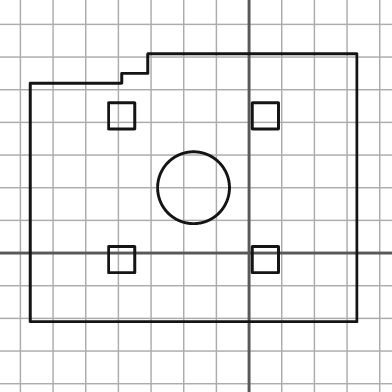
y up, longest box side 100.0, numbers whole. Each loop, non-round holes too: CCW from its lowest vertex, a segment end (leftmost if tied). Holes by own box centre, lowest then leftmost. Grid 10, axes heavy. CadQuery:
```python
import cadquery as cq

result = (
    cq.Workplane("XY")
    .moveTo(-67.0, -21.0)
    .lineTo(33.0, -21.0)
    .lineTo(33.0, 61.0)
    .lineTo(-31.0, 61.0)
    .lineTo(-31.0, 55.0)
    .lineTo(-39.0, 55.0)
    .lineTo(-39.0, 52.0)
    .lineTo(-67.0, 52.0)
    .close()
    .moveTo(-43.0, -6.0)
    .lineTo(-35.0, -6.0)
    .lineTo(-35.0, 2.0)
    .lineTo(-43.0, 2.0)
    .close()
    .moveTo(1.0, -6.0)
    .lineTo(9.0, -6.0)
    .lineTo(9.0, 2.0)
    .lineTo(1.0, 2.0)
    .close()
    .moveTo(-17.0, 20.0)
    .circle(11.0)
    .moveTo(-43.0, 38.0)
    .lineTo(-35.0, 38.0)
    .lineTo(-35.0, 46.0)
    .lineTo(-43.0, 46.0)
    .close()
    .moveTo(1.0, 38.0)
    .lineTo(9.0, 38.0)
    .lineTo(9.0, 46.0)
    .lineTo(1.0, 46.0)
    .close()
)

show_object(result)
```